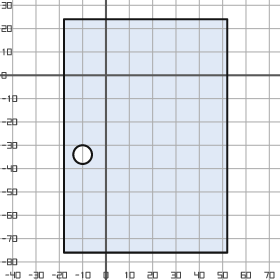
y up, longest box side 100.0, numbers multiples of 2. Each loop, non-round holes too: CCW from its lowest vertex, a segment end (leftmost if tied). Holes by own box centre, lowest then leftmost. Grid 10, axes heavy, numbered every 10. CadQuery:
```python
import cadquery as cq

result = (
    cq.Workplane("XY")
    .moveTo(-18.0, -76.0)
    .lineTo(52.0, -76.0)
    .lineTo(52.0, 24.0)
    .lineTo(-18.0, 24.0)
    .close()
    .moveTo(-10.0, -34.0)
    .circle(4.0)
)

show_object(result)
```